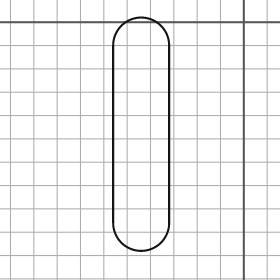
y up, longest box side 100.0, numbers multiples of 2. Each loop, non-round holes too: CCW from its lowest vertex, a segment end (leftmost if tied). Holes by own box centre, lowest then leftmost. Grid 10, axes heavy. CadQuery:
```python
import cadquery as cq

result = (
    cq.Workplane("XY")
    .moveTo(-56.0, -86.0)
    .threePointArc((-44.0, -98.0), (-32.0, -86.0))
    .lineTo(-32.0, -10.0)
    .threePointArc((-44.0, 2.0), (-56.0, -10.0))
    .close()
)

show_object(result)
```